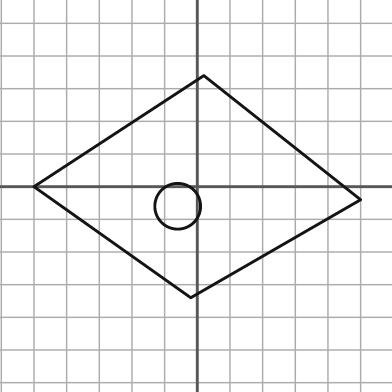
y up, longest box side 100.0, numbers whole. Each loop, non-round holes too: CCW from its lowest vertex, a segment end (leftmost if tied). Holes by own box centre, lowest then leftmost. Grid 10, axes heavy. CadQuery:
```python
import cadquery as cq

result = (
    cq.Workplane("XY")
    .moveTo(-2.0, -34.0)
    .lineTo(50.0, -4.0)
    .lineTo(2.0, 34.0)
    .lineTo(-50.0, 0.0)
    .close()
    .moveTo(-6.0, -6.0)
    .circle(7.0)
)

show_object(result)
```